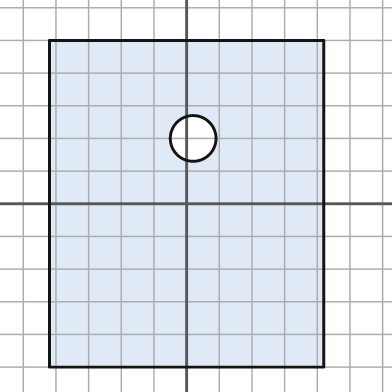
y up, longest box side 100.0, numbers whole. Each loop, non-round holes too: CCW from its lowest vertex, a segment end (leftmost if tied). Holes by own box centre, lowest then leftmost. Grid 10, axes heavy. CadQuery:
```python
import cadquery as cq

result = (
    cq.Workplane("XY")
    .moveTo(-42.0, -50.0)
    .lineTo(42.0, -50.0)
    .lineTo(42.0, 50.0)
    .lineTo(-42.0, 50.0)
    .close()
    .moveTo(2.0, 20.0)
    .circle(7.0)
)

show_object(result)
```